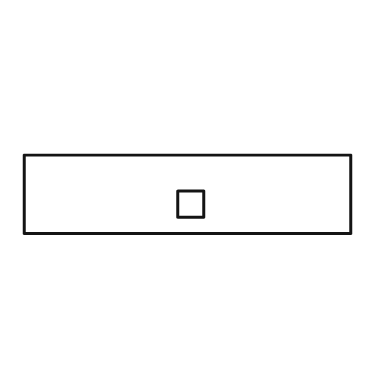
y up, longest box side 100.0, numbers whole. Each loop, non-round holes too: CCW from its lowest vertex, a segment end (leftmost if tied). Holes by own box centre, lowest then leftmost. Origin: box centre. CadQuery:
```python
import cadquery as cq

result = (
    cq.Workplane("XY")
    .moveTo(-50.0, -12.0)
    .lineTo(50.0, -12.0)
    .lineTo(50.0, 12.0)
    .lineTo(-50.0, 12.0)
    .close()
    .moveTo(-3.0, -7.0)
    .lineTo(5.0, -7.0)
    .lineTo(5.0, 1.0)
    .lineTo(-3.0, 1.0)
    .close()
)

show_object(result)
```